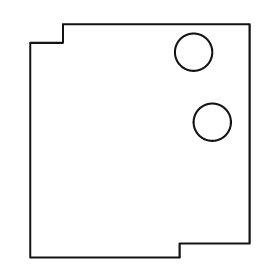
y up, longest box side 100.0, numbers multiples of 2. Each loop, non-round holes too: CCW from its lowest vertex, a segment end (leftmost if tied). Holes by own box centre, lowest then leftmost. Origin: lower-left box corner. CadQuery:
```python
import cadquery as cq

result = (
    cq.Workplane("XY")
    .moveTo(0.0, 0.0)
    .lineTo(64.0, 0.0)
    .lineTo(64.0, 6.0)
    .lineTo(94.0, 6.0)
    .lineTo(94.0, 100.0)
    .lineTo(14.0, 100.0)
    .lineTo(14.0, 92.0)
    .lineTo(0.0, 92.0)
    .close()
    .moveTo(78.0, 58.0)
    .circle(8.0)
    .moveTo(70.0, 88.0)
    .circle(8.0)
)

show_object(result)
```